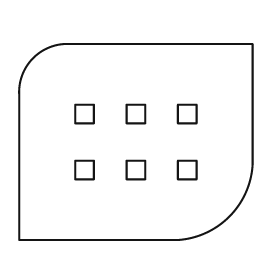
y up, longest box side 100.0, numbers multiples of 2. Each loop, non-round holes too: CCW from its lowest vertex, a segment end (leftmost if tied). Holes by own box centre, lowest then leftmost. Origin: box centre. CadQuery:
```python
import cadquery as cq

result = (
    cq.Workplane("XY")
    .moveTo(-50.0, -42.0)
    .lineTo(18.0, -42.0)
    .threePointArc((40.0, -32.0), (50.0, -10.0))
    .lineTo(50.0, 42.0)
    .lineTo(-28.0, 42.0)
    .threePointArc((-44.0, 36.0), (-50.0, 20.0))
    .close()
    .moveTo(-26.0, -16.0)
    .lineTo(-18.0, -16.0)
    .lineTo(-18.0, -8.0)
    .lineTo(-26.0, -8.0)
    .close()
    .moveTo(-4.0, -16.0)
    .lineTo(4.0, -16.0)
    .lineTo(4.0, -8.0)
    .lineTo(-4.0, -8.0)
    .close()
    .moveTo(18.0, -16.0)
    .lineTo(26.0, -16.0)
    .lineTo(26.0, -8.0)
    .lineTo(18.0, -8.0)
    .close()
    .moveTo(-26.0, 8.0)
    .lineTo(-18.0, 8.0)
    .lineTo(-18.0, 16.0)
    .lineTo(-26.0, 16.0)
    .close()
    .moveTo(-4.0, 8.0)
    .lineTo(4.0, 8.0)
    .lineTo(4.0, 16.0)
    .lineTo(-4.0, 16.0)
    .close()
    .moveTo(18.0, 8.0)
    .lineTo(26.0, 8.0)
    .lineTo(26.0, 16.0)
    .lineTo(18.0, 16.0)
    .close()
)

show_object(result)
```